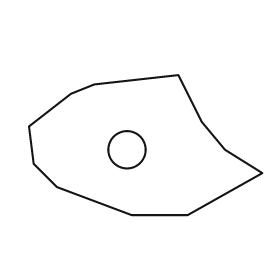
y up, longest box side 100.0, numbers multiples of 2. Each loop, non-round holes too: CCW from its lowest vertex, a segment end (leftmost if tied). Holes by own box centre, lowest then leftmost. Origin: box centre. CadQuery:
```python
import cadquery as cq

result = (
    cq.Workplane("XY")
    .moveTo(-6.0, -30.0)
    .lineTo(18.0, -30.0)
    .lineTo(50.0, -12.0)
    .lineTo(34.0, -2.0)
    .lineTo(24.0, 10.0)
    .lineTo(14.0, 30.0)
    .lineTo(-22.0, 26.0)
    .lineTo(-32.0, 22.0)
    .lineTo(-50.0, 8.0)
    .lineTo(-48.0, -8.0)
    .lineTo(-38.0, -18.0)
    .close()
    .moveTo(-8.0, -2.0)
    .circle(8.0)
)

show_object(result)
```